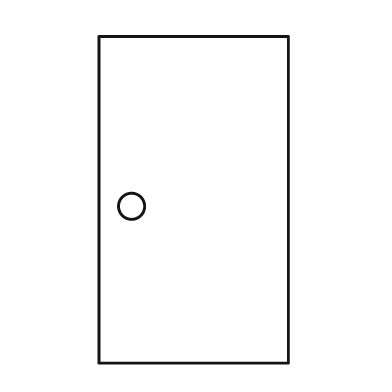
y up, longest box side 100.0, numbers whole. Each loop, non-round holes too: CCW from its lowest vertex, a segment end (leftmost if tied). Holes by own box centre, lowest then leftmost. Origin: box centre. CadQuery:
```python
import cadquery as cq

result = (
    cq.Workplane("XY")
    .moveTo(-29.0, -50.0)
    .lineTo(29.0, -50.0)
    .lineTo(29.0, 50.0)
    .lineTo(-29.0, 50.0)
    .close()
    .moveTo(-19.0, -2.0)
    .circle(4.0)
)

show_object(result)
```